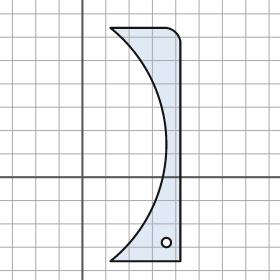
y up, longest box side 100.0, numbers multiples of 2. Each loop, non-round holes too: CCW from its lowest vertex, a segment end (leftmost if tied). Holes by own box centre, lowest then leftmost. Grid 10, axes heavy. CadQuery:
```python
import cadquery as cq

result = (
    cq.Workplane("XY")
    .moveTo(12.0, -36.0)
    .lineTo(42.0, -36.0)
    .lineTo(42.0, 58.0)
    .threePointArc((40.0, 62.0), (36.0, 64.0))
    .lineTo(12.0, 64.0)
    .threePointArc((36.0, 14.0), (12.0, -36.0))
    .close()
    .moveTo(36.0, -28.0)
    .circle(2.0)
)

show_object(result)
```